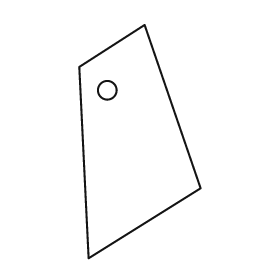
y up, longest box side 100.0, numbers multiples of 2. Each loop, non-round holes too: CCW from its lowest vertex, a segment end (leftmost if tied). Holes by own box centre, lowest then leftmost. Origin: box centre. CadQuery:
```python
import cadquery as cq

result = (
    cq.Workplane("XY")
    .moveTo(-22.0, -50.0)
    .lineTo(26.0, -20.0)
    .lineTo(2.0, 50.0)
    .lineTo(-26.0, 32.0)
    .close()
    .moveTo(-14.0, 22.0)
    .circle(4.0)
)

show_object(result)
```